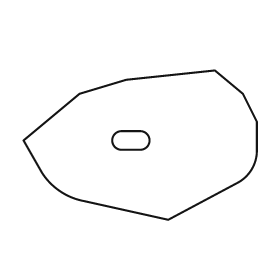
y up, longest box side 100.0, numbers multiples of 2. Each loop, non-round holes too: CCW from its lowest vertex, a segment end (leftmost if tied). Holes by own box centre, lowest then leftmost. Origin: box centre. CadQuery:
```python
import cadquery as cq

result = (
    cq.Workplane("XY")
    .moveTo(12.0, -32.0)
    .lineTo(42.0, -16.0)
    .threePointArc((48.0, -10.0), (50.0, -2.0))
    .lineTo(50.0, 10.0)
    .lineTo(44.0, 22.0)
    .lineTo(32.0, 32.0)
    .lineTo(-6.0, 28.0)
    .lineTo(-26.0, 22.0)
    .lineTo(-50.0, 2.0)
    .lineTo(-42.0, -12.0)
    .threePointArc((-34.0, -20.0), (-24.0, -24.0))
    .close()
    .moveTo(-8.0, -2.0)
    .lineTo(0.0, -2.0)
    .threePointArc((4.0, 2.0), (0.0, 6.0))
    .lineTo(-8.0, 6.0)
    .threePointArc((-12.0, 2.0), (-8.0, -2.0))
    .close()
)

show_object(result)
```